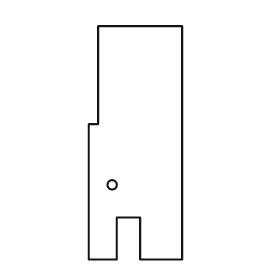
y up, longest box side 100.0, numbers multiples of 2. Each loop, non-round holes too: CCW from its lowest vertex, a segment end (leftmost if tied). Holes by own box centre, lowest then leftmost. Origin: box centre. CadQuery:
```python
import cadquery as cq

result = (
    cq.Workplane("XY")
    .moveTo(-20.0, -50.0)
    .lineTo(-8.0, -50.0)
    .lineTo(-8.0, -32.0)
    .lineTo(2.0, -32.0)
    .lineTo(2.0, -50.0)
    .lineTo(20.0, -50.0)
    .lineTo(20.0, 50.0)
    .lineTo(-16.0, 50.0)
    .lineTo(-16.0, 8.0)
    .lineTo(-20.0, 8.0)
    .close()
    .moveTo(-10.0, -18.0)
    .circle(2.0)
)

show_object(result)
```